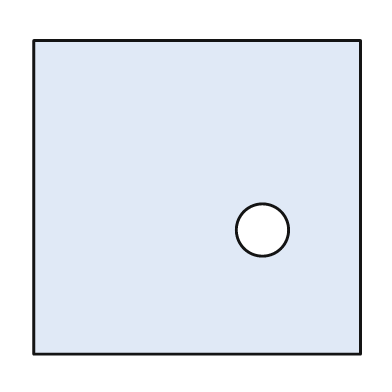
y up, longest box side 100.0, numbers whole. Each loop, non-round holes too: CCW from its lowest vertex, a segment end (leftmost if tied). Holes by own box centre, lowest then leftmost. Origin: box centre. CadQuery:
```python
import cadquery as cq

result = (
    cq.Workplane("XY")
    .moveTo(-50.0, -48.0)
    .lineTo(50.0, -48.0)
    .lineTo(50.0, 48.0)
    .lineTo(-50.0, 48.0)
    .close()
    .moveTo(20.0, -10.0)
    .circle(8.0)
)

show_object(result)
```